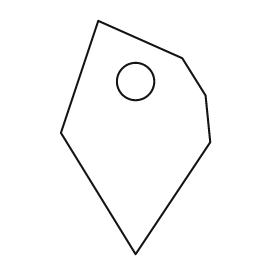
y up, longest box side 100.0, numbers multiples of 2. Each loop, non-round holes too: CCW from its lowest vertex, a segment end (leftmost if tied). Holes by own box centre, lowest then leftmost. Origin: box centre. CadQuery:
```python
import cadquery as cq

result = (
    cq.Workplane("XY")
    .moveTo(0.0, -50.0)
    .lineTo(32.0, -2.0)
    .lineTo(30.0, 18.0)
    .lineTo(20.0, 34.0)
    .lineTo(-16.0, 50.0)
    .lineTo(-32.0, 2.0)
    .close()
    .moveTo(0.0, 24.0)
    .circle(8.0)
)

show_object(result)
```